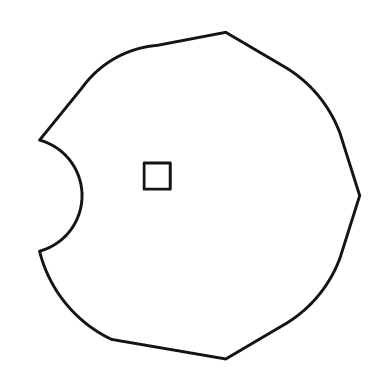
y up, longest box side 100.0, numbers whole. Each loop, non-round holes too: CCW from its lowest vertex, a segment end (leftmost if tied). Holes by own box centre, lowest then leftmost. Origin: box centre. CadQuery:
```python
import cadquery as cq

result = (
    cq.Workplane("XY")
    .moveTo(8.0, -50.0)
    .lineTo(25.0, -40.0)
    .threePointArc((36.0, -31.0), (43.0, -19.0))
    .lineTo(49.0, 0.0)
    .lineTo(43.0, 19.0)
    .threePointArc((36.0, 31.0), (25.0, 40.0))
    .lineTo(8.0, 50.0)
    .lineTo(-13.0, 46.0)
    .threePointArc((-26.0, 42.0), (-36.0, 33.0))
    .lineTo(-49.0, 17.0)
    .threePointArc((-36.0, 0.0), (-49.0, -17.0))
    .threePointArc((-41.0, -33.0), (-27.0, -44.0))
    .close()
    .moveTo(-17.0, 2.0)
    .lineTo(-9.0, 2.0)
    .lineTo(-9.0, 10.0)
    .lineTo(-17.0, 10.0)
    .close()
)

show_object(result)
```